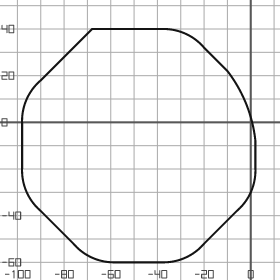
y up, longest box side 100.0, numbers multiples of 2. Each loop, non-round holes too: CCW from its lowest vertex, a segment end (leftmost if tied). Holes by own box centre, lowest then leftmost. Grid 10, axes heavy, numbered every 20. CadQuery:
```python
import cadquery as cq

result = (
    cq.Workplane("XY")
    .moveTo(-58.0, -60.0)
    .lineTo(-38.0, -60.0)
    .threePointArc((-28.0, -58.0), (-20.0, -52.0))
    .lineTo(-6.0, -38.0)
    .threePointArc((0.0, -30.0), (2.0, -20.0))
    .lineTo(2.0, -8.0)
    .threePointArc((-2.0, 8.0), (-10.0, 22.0))
    .lineTo(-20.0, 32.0)
    .threePointArc((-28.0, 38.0), (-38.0, 40.0))
    .lineTo(-68.0, 40.0)
    .lineTo(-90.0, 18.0)
    .threePointArc((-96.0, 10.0), (-98.0, 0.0))
    .lineTo(-98.0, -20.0)
    .threePointArc((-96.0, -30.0), (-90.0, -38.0))
    .lineTo(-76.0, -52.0)
    .threePointArc((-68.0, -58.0), (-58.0, -60.0))
    .close()
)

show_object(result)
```